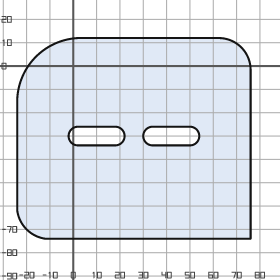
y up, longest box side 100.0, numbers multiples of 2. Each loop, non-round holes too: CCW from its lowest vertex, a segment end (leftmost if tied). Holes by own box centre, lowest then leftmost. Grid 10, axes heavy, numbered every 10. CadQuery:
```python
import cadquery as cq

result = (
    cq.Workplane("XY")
    .moveTo(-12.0, -74.0)
    .lineTo(76.0, -74.0)
    .lineTo(76.0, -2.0)
    .threePointArc((72.0, 8.0), (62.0, 12.0))
    .lineTo(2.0, 12.0)
    .threePointArc((-16.0, 4.0), (-24.0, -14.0))
    .lineTo(-24.0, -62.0)
    .threePointArc((-20.0, -70.0), (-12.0, -74.0))
    .close()
    .moveTo(2.0, -34.0)
    .lineTo(18.0, -34.0)
    .threePointArc((22.0, -30.0), (18.0, -26.0))
    .lineTo(2.0, -26.0)
    .threePointArc((-2.0, -30.0), (2.0, -34.0))
    .close()
    .moveTo(34.0, -34.0)
    .lineTo(50.0, -34.0)
    .threePointArc((54.0, -30.0), (50.0, -26.0))
    .lineTo(34.0, -26.0)
    .threePointArc((30.0, -30.0), (34.0, -34.0))
    .close()
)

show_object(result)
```